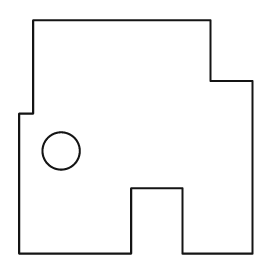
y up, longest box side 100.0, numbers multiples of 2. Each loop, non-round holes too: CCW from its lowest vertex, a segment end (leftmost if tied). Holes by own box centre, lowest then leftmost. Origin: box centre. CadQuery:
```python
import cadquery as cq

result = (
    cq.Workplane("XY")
    .moveTo(-50.0, -50.0)
    .lineTo(-2.0, -50.0)
    .lineTo(-2.0, -22.0)
    .lineTo(20.0, -22.0)
    .lineTo(20.0, -50.0)
    .lineTo(50.0, -50.0)
    .lineTo(50.0, 24.0)
    .lineTo(32.0, 24.0)
    .lineTo(32.0, 50.0)
    .lineTo(-44.0, 50.0)
    .lineTo(-44.0, 10.0)
    .lineTo(-50.0, 10.0)
    .close()
    .moveTo(-32.0, -6.0)
    .circle(8.0)
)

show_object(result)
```